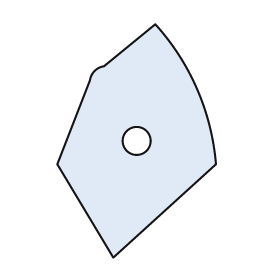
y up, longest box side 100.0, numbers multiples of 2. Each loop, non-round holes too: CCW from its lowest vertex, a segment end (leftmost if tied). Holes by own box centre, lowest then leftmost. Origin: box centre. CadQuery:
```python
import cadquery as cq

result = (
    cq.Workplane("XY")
    .moveTo(-10.0, -50.0)
    .lineTo(34.0, -10.0)
    .threePointArc((26.0, 22.0), (8.0, 50.0))
    .lineTo(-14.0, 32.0)
    .threePointArc((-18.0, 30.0), (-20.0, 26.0))
    .lineTo(-34.0, -10.0)
    .close()
    .moveTo(0.0, 0.0)
    .circle(6.0)
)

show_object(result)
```